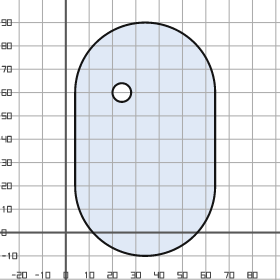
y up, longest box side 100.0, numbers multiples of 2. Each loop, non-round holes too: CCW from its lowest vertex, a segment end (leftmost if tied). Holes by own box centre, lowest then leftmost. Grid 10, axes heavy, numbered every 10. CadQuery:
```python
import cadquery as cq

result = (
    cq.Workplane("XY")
    .moveTo(4.0, 20.0)
    .threePointArc((34.0, -10.0), (64.0, 20.0))
    .lineTo(64.0, 60.0)
    .threePointArc((34.0, 90.0), (4.0, 60.0))
    .close()
    .moveTo(24.0, 60.0)
    .circle(4.0)
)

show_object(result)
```